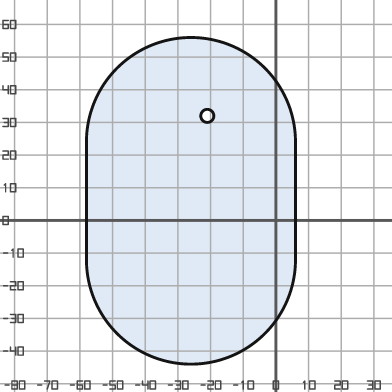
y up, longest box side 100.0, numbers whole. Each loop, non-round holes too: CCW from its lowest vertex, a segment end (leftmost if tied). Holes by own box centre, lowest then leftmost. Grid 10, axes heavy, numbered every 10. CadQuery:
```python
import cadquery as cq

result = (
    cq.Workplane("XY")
    .moveTo(-58.0, -12.0)
    .threePointArc((-26.0, -44.0), (6.0, -12.0))
    .lineTo(6.0, 24.0)
    .threePointArc((-26.0, 56.0), (-58.0, 24.0))
    .close()
    .moveTo(-21.0, 32.0)
    .circle(2.0)
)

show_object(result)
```